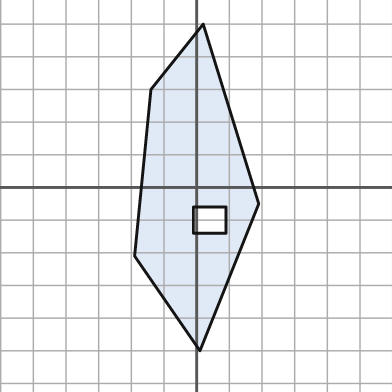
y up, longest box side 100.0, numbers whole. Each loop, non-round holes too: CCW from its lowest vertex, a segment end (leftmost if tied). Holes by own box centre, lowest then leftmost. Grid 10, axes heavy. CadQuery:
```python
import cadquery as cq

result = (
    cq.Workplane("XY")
    .moveTo(1.0, -50.0)
    .lineTo(19.0, -5.0)
    .lineTo(2.0, 50.0)
    .lineTo(-14.0, 30.0)
    .lineTo(-19.0, -21.0)
    .close()
    .moveTo(-1.0, -14.0)
    .lineTo(9.0, -14.0)
    .lineTo(9.0, -6.0)
    .lineTo(-1.0, -6.0)
    .close()
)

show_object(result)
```